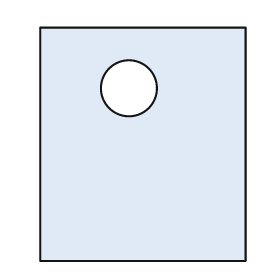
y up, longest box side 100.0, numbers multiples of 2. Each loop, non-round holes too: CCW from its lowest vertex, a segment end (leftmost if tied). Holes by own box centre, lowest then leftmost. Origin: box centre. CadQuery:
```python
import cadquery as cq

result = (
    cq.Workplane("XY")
    .moveTo(-44.0, -50.0)
    .lineTo(44.0, -50.0)
    .lineTo(44.0, 50.0)
    .lineTo(-44.0, 50.0)
    .close()
    .moveTo(-6.0, 24.0)
    .circle(12.0)
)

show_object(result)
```